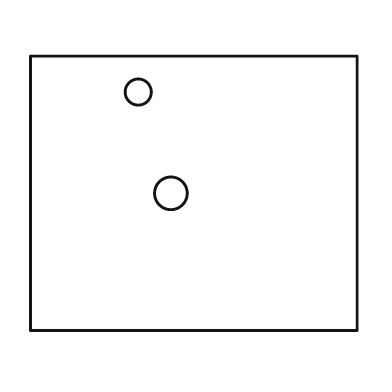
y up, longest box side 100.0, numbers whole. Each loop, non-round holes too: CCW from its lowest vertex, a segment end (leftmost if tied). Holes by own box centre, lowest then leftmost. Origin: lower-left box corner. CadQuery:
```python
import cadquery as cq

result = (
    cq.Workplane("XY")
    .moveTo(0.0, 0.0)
    .lineTo(100.0, 0.0)
    .lineTo(100.0, 84.0)
    .lineTo(0.0, 84.0)
    .close()
    .moveTo(43.0, 42.0)
    .circle(5.0)
    .moveTo(33.0, 73.0)
    .circle(4.0)
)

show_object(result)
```